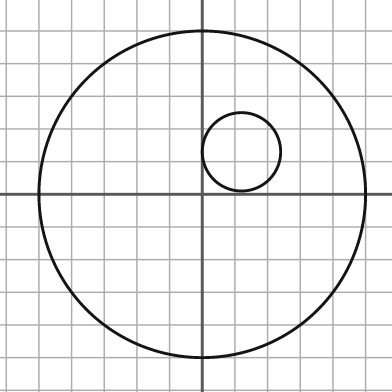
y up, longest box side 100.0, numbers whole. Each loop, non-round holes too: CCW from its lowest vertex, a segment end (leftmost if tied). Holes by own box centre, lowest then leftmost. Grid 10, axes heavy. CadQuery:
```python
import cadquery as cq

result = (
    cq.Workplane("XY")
    .moveTo(0.0, 0.0)
    .circle(50.0)
    .moveTo(12.0, 13.0)
    .circle(12.0)
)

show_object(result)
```